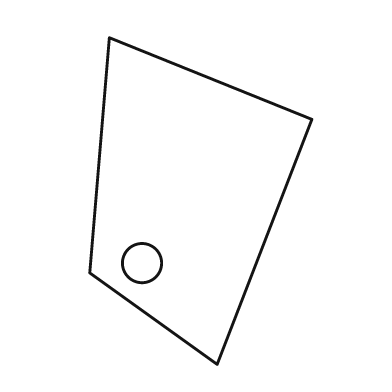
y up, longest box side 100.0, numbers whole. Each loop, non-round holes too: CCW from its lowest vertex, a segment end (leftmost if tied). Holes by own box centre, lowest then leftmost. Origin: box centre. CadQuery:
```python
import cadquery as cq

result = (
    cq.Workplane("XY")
    .moveTo(5.0, -50.0)
    .lineTo(34.0, 25.0)
    .lineTo(-28.0, 50.0)
    .lineTo(-34.0, -22.0)
    .close()
    .moveTo(-18.0, -19.0)
    .circle(6.0)
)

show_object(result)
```